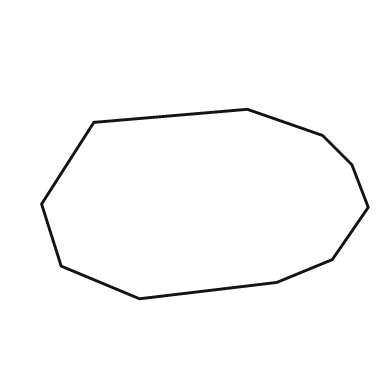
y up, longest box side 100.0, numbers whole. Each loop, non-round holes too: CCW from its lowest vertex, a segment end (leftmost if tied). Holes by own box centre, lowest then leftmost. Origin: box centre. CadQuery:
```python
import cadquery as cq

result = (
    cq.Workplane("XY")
    .moveTo(-20.0, -29.0)
    .lineTo(22.0, -24.0)
    .lineTo(39.0, -17.0)
    .lineTo(50.0, -1.0)
    .lineTo(45.0, 12.0)
    .lineTo(36.0, 21.0)
    .lineTo(13.0, 29.0)
    .lineTo(-34.0, 25.0)
    .lineTo(-50.0, 0.0)
    .lineTo(-44.0, -19.0)
    .close()
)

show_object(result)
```